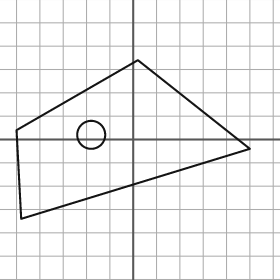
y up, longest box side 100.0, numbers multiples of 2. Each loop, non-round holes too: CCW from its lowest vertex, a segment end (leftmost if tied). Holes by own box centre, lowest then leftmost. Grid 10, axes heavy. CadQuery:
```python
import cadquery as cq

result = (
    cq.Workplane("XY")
    .moveTo(-48.0, -34.0)
    .lineTo(50.0, -4.0)
    .lineTo(2.0, 34.0)
    .lineTo(-50.0, 4.0)
    .close()
    .moveTo(-18.0, 2.0)
    .circle(6.0)
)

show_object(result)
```